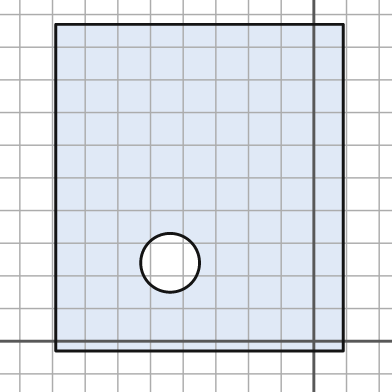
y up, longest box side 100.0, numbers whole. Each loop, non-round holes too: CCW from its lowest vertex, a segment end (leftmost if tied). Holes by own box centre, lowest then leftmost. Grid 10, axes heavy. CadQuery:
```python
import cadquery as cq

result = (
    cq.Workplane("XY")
    .moveTo(-79.0, -3.0)
    .lineTo(9.0, -3.0)
    .lineTo(9.0, 97.0)
    .lineTo(-79.0, 97.0)
    .close()
    .moveTo(-44.0, 24.0)
    .circle(9.0)
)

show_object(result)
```